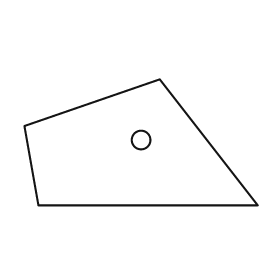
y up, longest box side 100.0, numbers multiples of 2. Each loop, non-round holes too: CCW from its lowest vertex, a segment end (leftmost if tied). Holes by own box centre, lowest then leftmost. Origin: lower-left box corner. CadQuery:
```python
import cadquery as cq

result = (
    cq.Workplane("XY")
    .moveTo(6.0, 0.0)
    .lineTo(100.0, 0.0)
    .lineTo(58.0, 54.0)
    .lineTo(0.0, 34.0)
    .close()
    .moveTo(50.0, 28.0)
    .circle(4.0)
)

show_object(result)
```